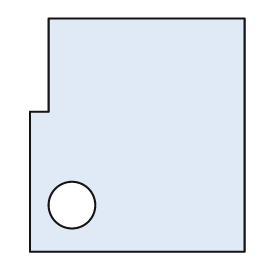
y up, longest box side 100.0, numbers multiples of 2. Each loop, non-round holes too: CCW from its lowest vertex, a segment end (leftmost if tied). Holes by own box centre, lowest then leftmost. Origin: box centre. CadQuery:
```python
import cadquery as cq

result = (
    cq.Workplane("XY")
    .moveTo(-46.0, -50.0)
    .lineTo(46.0, -50.0)
    .lineTo(46.0, 50.0)
    .lineTo(-38.0, 50.0)
    .lineTo(-38.0, 10.0)
    .lineTo(-46.0, 10.0)
    .close()
    .moveTo(-28.0, -30.0)
    .circle(10.0)
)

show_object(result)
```